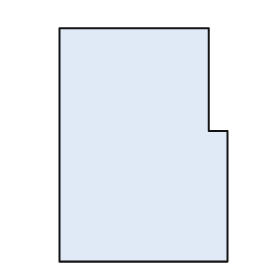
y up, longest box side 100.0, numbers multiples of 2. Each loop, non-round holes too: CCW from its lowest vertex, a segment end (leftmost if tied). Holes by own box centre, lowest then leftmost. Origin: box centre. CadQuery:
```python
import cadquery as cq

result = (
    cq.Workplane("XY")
    .moveTo(-36.0, -50.0)
    .lineTo(36.0, -50.0)
    .lineTo(36.0, 6.0)
    .lineTo(28.0, 6.0)
    .lineTo(28.0, 50.0)
    .lineTo(-36.0, 50.0)
    .close()
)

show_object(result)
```